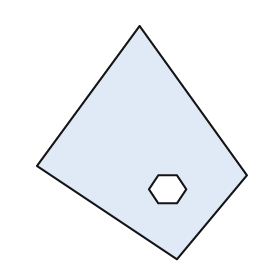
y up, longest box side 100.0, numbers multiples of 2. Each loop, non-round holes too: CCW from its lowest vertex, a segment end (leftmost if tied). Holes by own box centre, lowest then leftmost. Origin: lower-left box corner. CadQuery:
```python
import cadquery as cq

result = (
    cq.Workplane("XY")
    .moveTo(60.0, 0.0)
    .lineTo(90.0, 36.0)
    .lineTo(44.0, 100.0)
    .lineTo(0.0, 40.0)
    .close()
    .moveTo(52.0, 24.0)
    .lineTo(60.0, 24.0)
    .lineTo(64.0, 30.0)
    .lineTo(60.0, 36.0)
    .lineTo(52.0, 36.0)
    .lineTo(48.0, 30.0)
    .close()
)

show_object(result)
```